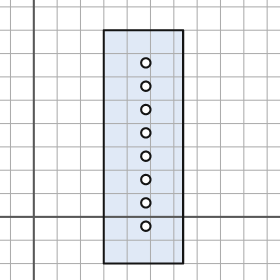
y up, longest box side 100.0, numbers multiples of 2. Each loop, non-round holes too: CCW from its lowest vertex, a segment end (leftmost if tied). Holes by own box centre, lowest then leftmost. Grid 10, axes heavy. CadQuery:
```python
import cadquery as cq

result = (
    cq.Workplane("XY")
    .moveTo(30.0, -20.0)
    .lineTo(64.0, -20.0)
    .lineTo(64.0, 80.0)
    .lineTo(30.0, 80.0)
    .close()
    .moveTo(48.0, -4.0)
    .circle(2.0)
    .moveTo(48.0, 6.0)
    .circle(2.0)
    .moveTo(48.0, 16.0)
    .circle(2.0)
    .moveTo(48.0, 26.0)
    .circle(2.0)
    .moveTo(48.0, 36.0)
    .circle(2.0)
    .moveTo(48.0, 46.0)
    .circle(2.0)
    .moveTo(48.0, 56.0)
    .circle(2.0)
    .moveTo(48.0, 66.0)
    .circle(2.0)
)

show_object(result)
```